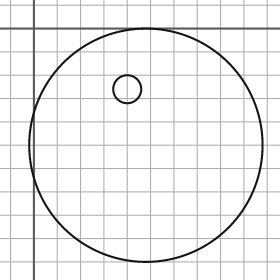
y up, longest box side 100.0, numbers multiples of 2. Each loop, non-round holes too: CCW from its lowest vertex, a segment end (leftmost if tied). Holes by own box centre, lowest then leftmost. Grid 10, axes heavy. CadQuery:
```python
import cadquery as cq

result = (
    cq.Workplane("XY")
    .moveTo(48.0, -50.0)
    .circle(50.0)
    .moveTo(40.0, -26.0)
    .circle(6.0)
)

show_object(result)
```